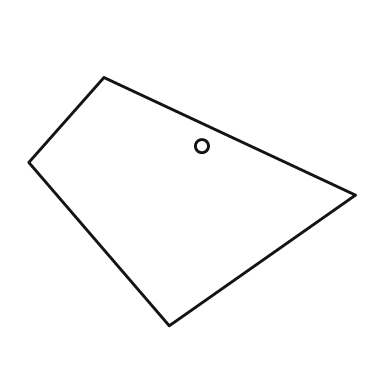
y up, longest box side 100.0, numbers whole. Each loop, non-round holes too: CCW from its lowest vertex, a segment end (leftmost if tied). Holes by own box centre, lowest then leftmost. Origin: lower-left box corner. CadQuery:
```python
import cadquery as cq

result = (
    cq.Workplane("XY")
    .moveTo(43.0, 0.0)
    .lineTo(100.0, 40.0)
    .lineTo(23.0, 76.0)
    .lineTo(0.0, 50.0)
    .close()
    .moveTo(53.0, 55.0)
    .circle(2.0)
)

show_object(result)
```